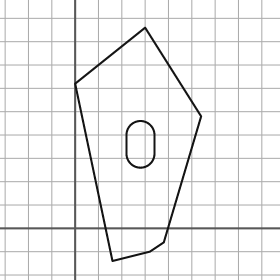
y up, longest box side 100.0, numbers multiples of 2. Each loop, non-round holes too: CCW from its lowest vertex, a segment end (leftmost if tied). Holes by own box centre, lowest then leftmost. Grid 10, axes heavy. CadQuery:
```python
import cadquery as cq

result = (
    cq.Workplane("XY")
    .moveTo(16.0, -14.0)
    .lineTo(32.0, -10.0)
    .lineTo(38.0, -6.0)
    .lineTo(54.0, 48.0)
    .lineTo(30.0, 86.0)
    .lineTo(0.0, 62.0)
    .close()
    .moveTo(22.0, 32.0)
    .threePointArc((28.0, 26.0), (34.0, 32.0))
    .lineTo(34.0, 40.0)
    .threePointArc((28.0, 46.0), (22.0, 40.0))
    .close()
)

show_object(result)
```